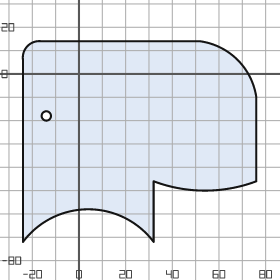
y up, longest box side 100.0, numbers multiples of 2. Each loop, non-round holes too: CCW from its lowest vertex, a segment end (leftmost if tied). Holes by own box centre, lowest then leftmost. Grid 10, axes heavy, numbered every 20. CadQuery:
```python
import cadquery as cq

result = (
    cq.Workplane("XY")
    .moveTo(-24.0, -72.0)
    .threePointArc((4.0, -58.0), (32.0, -72.0))
    .lineTo(32.0, -46.0)
    .threePointArc((54.0, -50.0), (76.0, -46.0))
    .lineTo(76.0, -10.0)
    .threePointArc((68.0, 6.0), (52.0, 14.0))
    .lineTo(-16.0, 14.0)
    .threePointArc((-22.0, 12.0), (-24.0, 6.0))
    .close()
    .moveTo(-14.0, -18.0)
    .circle(2.0)
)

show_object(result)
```